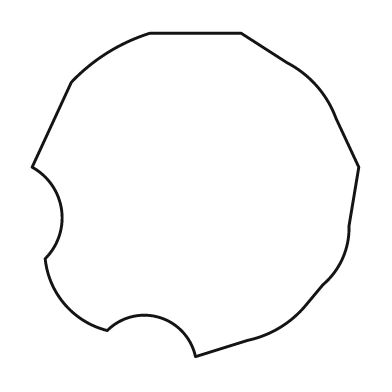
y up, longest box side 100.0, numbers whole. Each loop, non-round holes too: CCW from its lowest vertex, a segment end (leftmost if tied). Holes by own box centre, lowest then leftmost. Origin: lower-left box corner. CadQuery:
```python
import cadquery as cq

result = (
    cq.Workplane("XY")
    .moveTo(50.0, 0.0)
    .lineTo(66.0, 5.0)
    .threePointArc((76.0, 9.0), (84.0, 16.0))
    .lineTo(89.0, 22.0)
    .threePointArc((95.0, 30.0), (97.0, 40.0))
    .lineTo(100.0, 58.0)
    .lineTo(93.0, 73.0)
    .threePointArc((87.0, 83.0), (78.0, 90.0))
    .lineTo(64.0, 99.0)
    .lineTo(36.0, 99.0)
    .threePointArc((23.0, 93.0), (12.0, 84.0))
    .lineTo(0.0, 58.0)
    .threePointArc((9.0, 45.0), (4.0, 30.0))
    .threePointArc((10.0, 16.0), (23.0, 8.0))
    .threePointArc((39.0, 12.0), (50.0, 0.0))
    .close()
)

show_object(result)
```